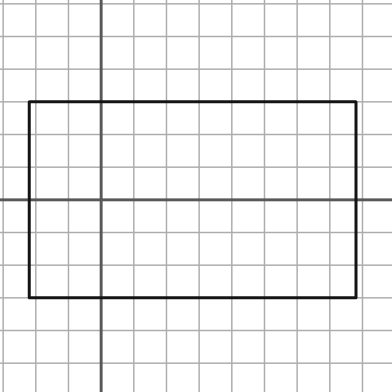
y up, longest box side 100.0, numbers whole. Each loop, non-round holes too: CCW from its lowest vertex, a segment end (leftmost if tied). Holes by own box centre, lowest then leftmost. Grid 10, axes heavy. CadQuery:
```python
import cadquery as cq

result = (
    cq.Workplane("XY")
    .moveTo(-22.0, -30.0)
    .lineTo(78.0, -30.0)
    .lineTo(78.0, 30.0)
    .lineTo(-22.0, 30.0)
    .close()
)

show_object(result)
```